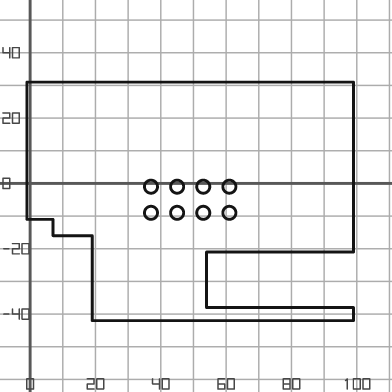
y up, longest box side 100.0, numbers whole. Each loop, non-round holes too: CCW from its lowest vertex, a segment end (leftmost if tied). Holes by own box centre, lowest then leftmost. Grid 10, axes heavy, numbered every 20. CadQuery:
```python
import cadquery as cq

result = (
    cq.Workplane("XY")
    .moveTo(19.0, -42.0)
    .lineTo(99.0, -42.0)
    .lineTo(99.0, -38.0)
    .lineTo(54.0, -38.0)
    .lineTo(54.0, -21.0)
    .lineTo(99.0, -21.0)
    .lineTo(99.0, 31.0)
    .lineTo(-1.0, 31.0)
    .lineTo(-1.0, -11.0)
    .lineTo(7.0, -11.0)
    .lineTo(7.0, -16.0)
    .lineTo(19.0, -16.0)
    .close()
    .moveTo(37.0, -9.0)
    .circle(2.0)
    .moveTo(45.0, -9.0)
    .circle(2.0)
    .moveTo(53.0, -9.0)
    .circle(2.0)
    .moveTo(61.0, -9.0)
    .circle(2.0)
    .moveTo(37.0, -1.0)
    .circle(2.0)
    .moveTo(45.0, -1.0)
    .circle(2.0)
    .moveTo(53.0, -1.0)
    .circle(2.0)
    .moveTo(61.0, -1.0)
    .circle(2.0)
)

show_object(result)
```